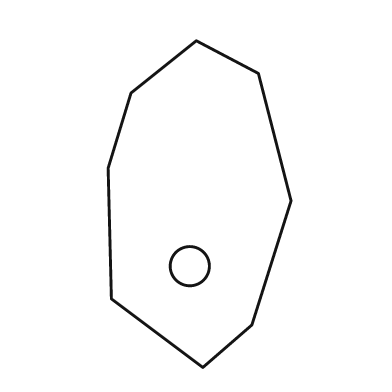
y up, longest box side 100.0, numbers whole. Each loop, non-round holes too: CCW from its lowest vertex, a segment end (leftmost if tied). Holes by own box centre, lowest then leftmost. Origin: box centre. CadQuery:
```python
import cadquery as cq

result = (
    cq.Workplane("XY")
    .moveTo(1.0, -50.0)
    .lineTo(16.0, -37.0)
    .lineTo(28.0, 1.0)
    .lineTo(18.0, 40.0)
    .lineTo(-1.0, 50.0)
    .lineTo(-21.0, 34.0)
    .lineTo(-28.0, 11.0)
    .lineTo(-27.0, -29.0)
    .close()
    .moveTo(-3.0, -19.0)
    .circle(6.0)
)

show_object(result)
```